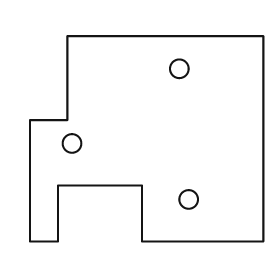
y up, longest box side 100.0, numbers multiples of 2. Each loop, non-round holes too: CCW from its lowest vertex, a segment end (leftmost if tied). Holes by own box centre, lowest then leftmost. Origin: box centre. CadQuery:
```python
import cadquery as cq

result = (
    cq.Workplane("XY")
    .moveTo(-50.0, -44.0)
    .lineTo(-38.0, -44.0)
    .lineTo(-38.0, -20.0)
    .lineTo(-2.0, -20.0)
    .lineTo(-2.0, -44.0)
    .lineTo(50.0, -44.0)
    .lineTo(50.0, 44.0)
    .lineTo(-34.0, 44.0)
    .lineTo(-34.0, 8.0)
    .lineTo(-50.0, 8.0)
    .close()
    .moveTo(18.0, -26.0)
    .circle(4.0)
    .moveTo(-32.0, -2.0)
    .circle(4.0)
    .moveTo(14.0, 30.0)
    .circle(4.0)
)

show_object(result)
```